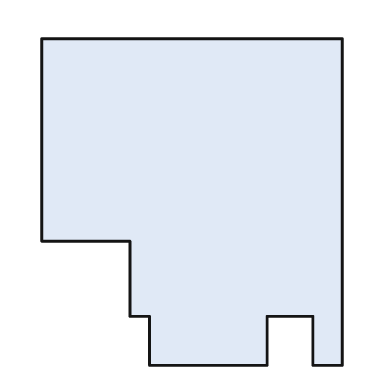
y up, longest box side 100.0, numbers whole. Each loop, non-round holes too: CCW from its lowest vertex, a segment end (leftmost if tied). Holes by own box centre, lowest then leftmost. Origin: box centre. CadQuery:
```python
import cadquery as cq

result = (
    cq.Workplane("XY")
    .moveTo(-13.0, -50.0)
    .lineTo(23.0, -50.0)
    .lineTo(23.0, -35.0)
    .lineTo(37.0, -35.0)
    .lineTo(37.0, -50.0)
    .lineTo(46.0, -50.0)
    .lineTo(46.0, 50.0)
    .lineTo(-46.0, 50.0)
    .lineTo(-46.0, -12.0)
    .lineTo(-19.0, -12.0)
    .lineTo(-19.0, -35.0)
    .lineTo(-13.0, -35.0)
    .close()
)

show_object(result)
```